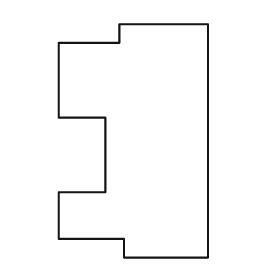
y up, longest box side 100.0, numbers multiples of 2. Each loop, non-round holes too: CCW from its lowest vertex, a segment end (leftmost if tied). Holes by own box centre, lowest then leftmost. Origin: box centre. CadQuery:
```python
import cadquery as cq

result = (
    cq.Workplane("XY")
    .moveTo(-4.0, -50.0)
    .lineTo(32.0, -50.0)
    .lineTo(32.0, 50.0)
    .lineTo(-6.0, 50.0)
    .lineTo(-6.0, 42.0)
    .lineTo(-32.0, 42.0)
    .lineTo(-32.0, 10.0)
    .lineTo(-12.0, 10.0)
    .lineTo(-12.0, -22.0)
    .lineTo(-32.0, -22.0)
    .lineTo(-32.0, -42.0)
    .lineTo(-4.0, -42.0)
    .close()
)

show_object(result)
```